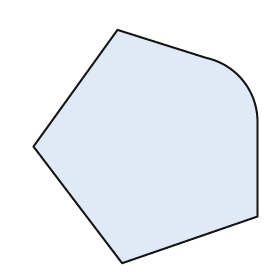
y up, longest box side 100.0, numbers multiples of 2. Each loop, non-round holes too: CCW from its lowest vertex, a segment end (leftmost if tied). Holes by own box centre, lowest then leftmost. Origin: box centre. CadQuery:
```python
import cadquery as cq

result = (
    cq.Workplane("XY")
    .moveTo(-10.0, -50.0)
    .lineTo(48.0, -30.0)
    .lineTo(48.0, 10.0)
    .threePointArc((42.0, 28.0), (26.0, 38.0))
    .lineTo(-12.0, 50.0)
    .lineTo(-48.0, 0.0)
    .close()
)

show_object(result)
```